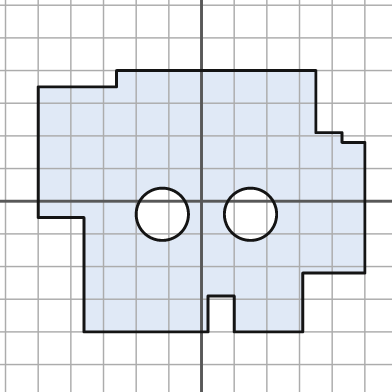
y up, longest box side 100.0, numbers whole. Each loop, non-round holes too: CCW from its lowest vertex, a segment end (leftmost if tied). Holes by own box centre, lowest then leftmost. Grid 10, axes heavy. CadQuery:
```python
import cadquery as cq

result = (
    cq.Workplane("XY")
    .moveTo(-36.0, -40.0)
    .lineTo(2.0, -40.0)
    .lineTo(2.0, -29.0)
    .lineTo(10.0, -29.0)
    .lineTo(10.0, -40.0)
    .lineTo(31.0, -40.0)
    .lineTo(31.0, -22.0)
    .lineTo(50.0, -22.0)
    .lineTo(50.0, 18.0)
    .lineTo(43.0, 18.0)
    .lineTo(43.0, 21.0)
    .lineTo(35.0, 21.0)
    .lineTo(35.0, 40.0)
    .lineTo(-26.0, 40.0)
    .lineTo(-26.0, 35.0)
    .lineTo(-50.0, 35.0)
    .lineTo(-50.0, -5.0)
    .lineTo(-36.0, -5.0)
    .close()
    .moveTo(-12.0, -4.0)
    .circle(8.0)
    .moveTo(15.0, -4.0)
    .circle(8.0)
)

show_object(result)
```